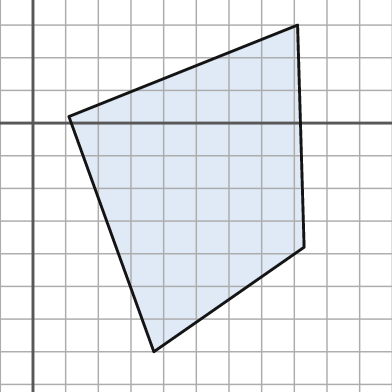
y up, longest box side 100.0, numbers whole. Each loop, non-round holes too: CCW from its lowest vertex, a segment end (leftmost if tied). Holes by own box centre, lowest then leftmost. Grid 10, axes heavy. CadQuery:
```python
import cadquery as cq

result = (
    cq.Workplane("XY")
    .moveTo(37.0, -70.0)
    .lineTo(83.0, -38.0)
    .lineTo(81.0, 30.0)
    .lineTo(11.0, 2.0)
    .close()
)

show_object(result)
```